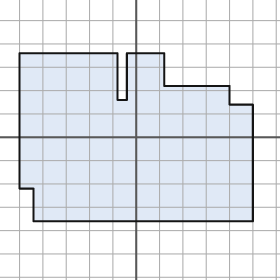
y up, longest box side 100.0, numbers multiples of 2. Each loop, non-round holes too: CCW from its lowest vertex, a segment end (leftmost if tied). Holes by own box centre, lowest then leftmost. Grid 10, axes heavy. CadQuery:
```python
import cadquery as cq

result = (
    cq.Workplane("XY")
    .moveTo(-44.0, -36.0)
    .lineTo(50.0, -36.0)
    .lineTo(50.0, 14.0)
    .lineTo(40.0, 14.0)
    .lineTo(40.0, 22.0)
    .lineTo(12.0, 22.0)
    .lineTo(12.0, 36.0)
    .lineTo(-4.0, 36.0)
    .lineTo(-4.0, 16.0)
    .lineTo(-8.0, 16.0)
    .lineTo(-8.0, 36.0)
    .lineTo(-50.0, 36.0)
    .lineTo(-50.0, -22.0)
    .lineTo(-44.0, -22.0)
    .close()
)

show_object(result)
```